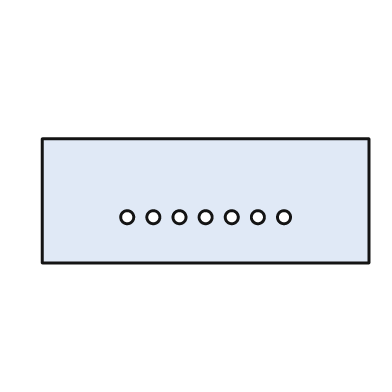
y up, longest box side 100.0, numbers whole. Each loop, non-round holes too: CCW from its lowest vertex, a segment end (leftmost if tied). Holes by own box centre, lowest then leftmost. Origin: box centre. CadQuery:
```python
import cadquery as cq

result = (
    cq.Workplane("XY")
    .moveTo(-50.0, -19.0)
    .lineTo(50.0, -19.0)
    .lineTo(50.0, 19.0)
    .lineTo(-50.0, 19.0)
    .close()
    .moveTo(-24.0, -5.0)
    .circle(2.0)
    .moveTo(-16.0, -5.0)
    .circle(2.0)
    .moveTo(-8.0, -5.0)
    .circle(2.0)
    .moveTo(0.0, -5.0)
    .circle(2.0)
    .moveTo(8.0, -5.0)
    .circle(2.0)
    .moveTo(16.0, -5.0)
    .circle(2.0)
    .moveTo(24.0, -5.0)
    .circle(2.0)
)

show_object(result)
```